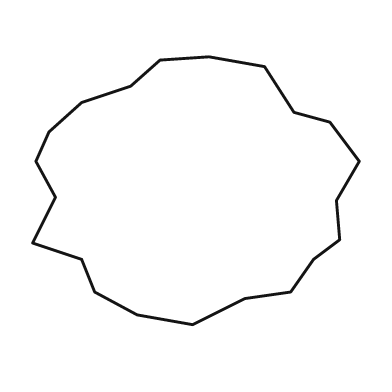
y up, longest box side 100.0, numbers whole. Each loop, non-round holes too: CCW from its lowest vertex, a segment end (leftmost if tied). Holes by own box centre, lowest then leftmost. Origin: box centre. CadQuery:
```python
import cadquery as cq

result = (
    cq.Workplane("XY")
    .moveTo(-1.0, -41.0)
    .lineTo(15.0, -33.0)
    .lineTo(29.0, -31.0)
    .lineTo(36.0, -21.0)
    .lineTo(44.0, -15.0)
    .lineTo(43.0, -3.0)
    .lineTo(50.0, 9.0)
    .lineTo(41.0, 21.0)
    .lineTo(30.0, 24.0)
    .lineTo(21.0, 38.0)
    .lineTo(4.0, 41.0)
    .lineTo(-11.0, 40.0)
    .lineTo(-20.0, 32.0)
    .lineTo(-35.0, 27.0)
    .lineTo(-45.0, 18.0)
    .lineTo(-49.0, 9.0)
    .lineTo(-43.0, -2.0)
    .lineTo(-50.0, -16.0)
    .lineTo(-35.0, -21.0)
    .lineTo(-31.0, -31.0)
    .lineTo(-18.0, -38.0)
    .close()
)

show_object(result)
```